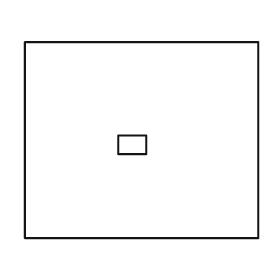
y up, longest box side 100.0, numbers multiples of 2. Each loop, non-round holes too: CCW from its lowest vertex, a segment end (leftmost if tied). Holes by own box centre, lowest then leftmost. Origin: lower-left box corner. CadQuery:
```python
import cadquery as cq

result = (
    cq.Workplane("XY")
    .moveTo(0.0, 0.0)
    .lineTo(100.0, 0.0)
    .lineTo(100.0, 84.0)
    .lineTo(0.0, 84.0)
    .close()
    .moveTo(40.0, 36.0)
    .lineTo(52.0, 36.0)
    .lineTo(52.0, 44.0)
    .lineTo(40.0, 44.0)
    .close()
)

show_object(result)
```